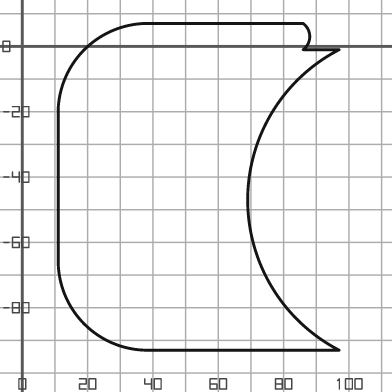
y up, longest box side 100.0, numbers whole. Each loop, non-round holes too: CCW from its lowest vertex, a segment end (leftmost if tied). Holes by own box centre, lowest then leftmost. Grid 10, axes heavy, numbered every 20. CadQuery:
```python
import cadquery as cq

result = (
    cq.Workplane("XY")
    .moveTo(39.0, -93.0)
    .lineTo(97.0, -93.0)
    .threePointArc((69.0, -47.0), (97.0, -1.0))
    .lineTo(86.0, -1.0)
    .threePointArc((88.0, 3.0), (86.0, 7.0))
    .lineTo(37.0, 7.0)
    .threePointArc((19.0, -1.0), (11.0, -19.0))
    .lineTo(11.0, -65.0)
    .threePointArc((19.0, -85.0), (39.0, -93.0))
    .close()
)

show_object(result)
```